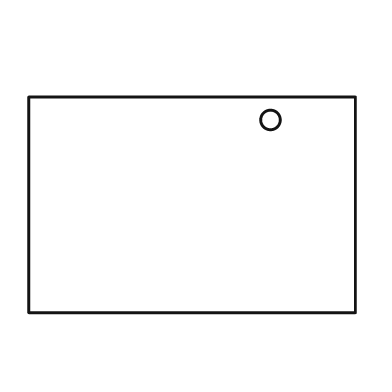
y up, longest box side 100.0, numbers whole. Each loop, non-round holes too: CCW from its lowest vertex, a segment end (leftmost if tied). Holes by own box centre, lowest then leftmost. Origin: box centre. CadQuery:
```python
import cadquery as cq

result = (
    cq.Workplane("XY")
    .moveTo(-50.0, -33.0)
    .lineTo(50.0, -33.0)
    .lineTo(50.0, 33.0)
    .lineTo(-50.0, 33.0)
    .close()
    .moveTo(24.0, 26.0)
    .circle(3.0)
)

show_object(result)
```